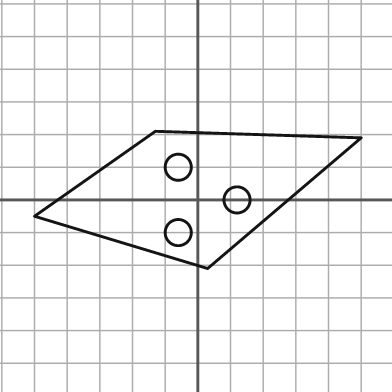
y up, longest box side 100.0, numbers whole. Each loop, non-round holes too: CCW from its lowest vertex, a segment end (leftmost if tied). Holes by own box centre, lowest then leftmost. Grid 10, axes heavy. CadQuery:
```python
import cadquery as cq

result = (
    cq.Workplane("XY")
    .moveTo(3.0, -21.0)
    .lineTo(50.0, 19.0)
    .lineTo(-13.0, 21.0)
    .lineTo(-50.0, -5.0)
    .close()
    .moveTo(-6.0, -10.0)
    .circle(4.0)
    .moveTo(12.0, 0.0)
    .circle(4.0)
    .moveTo(-6.0, 10.0)
    .circle(4.0)
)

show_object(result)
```